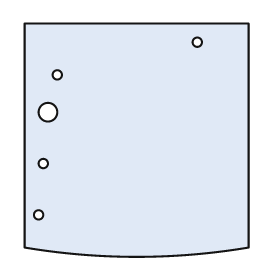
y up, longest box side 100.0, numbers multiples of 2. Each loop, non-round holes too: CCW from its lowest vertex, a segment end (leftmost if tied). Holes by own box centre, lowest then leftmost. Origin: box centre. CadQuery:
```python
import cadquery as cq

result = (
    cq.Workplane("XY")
    .moveTo(-48.0, -46.0)
    .threePointArc((0.0, -50.0), (48.0, -46.0))
    .lineTo(48.0, 50.0)
    .lineTo(-48.0, 50.0)
    .close()
    .moveTo(-42.0, -32.0)
    .circle(2.0)
    .moveTo(-40.0, -10.0)
    .circle(2.0)
    .moveTo(-38.0, 12.0)
    .circle(4.0)
    .moveTo(-34.0, 28.0)
    .circle(2.0)
    .moveTo(26.0, 42.0)
    .circle(2.0)
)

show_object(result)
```